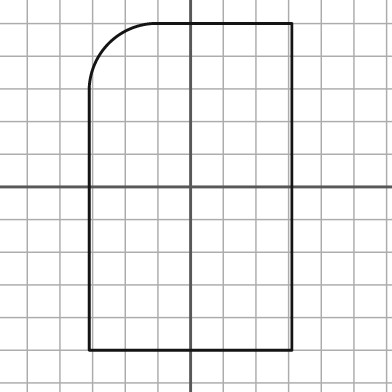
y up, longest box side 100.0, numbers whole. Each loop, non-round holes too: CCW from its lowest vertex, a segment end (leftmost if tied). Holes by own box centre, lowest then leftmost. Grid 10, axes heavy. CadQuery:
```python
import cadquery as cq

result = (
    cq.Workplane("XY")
    .moveTo(-31.0, -50.0)
    .lineTo(31.0, -50.0)
    .lineTo(31.0, 50.0)
    .lineTo(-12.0, 50.0)
    .threePointArc((-25.0, 44.0), (-31.0, 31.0))
    .close()
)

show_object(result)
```